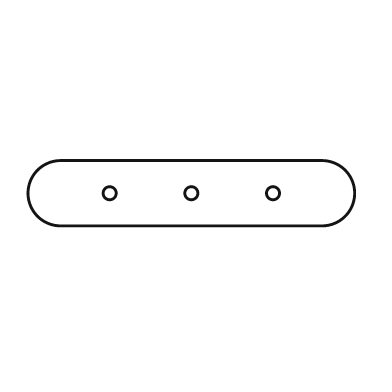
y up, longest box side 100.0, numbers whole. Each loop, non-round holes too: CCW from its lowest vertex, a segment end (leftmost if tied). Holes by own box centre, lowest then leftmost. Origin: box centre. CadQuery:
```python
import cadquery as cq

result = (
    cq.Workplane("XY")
    .moveTo(-40.0, -10.0)
    .lineTo(40.0, -10.0)
    .threePointArc((50.0, 0.0), (40.0, 10.0))
    .lineTo(-40.0, 10.0)
    .threePointArc((-50.0, 0.0), (-40.0, -10.0))
    .close()
    .moveTo(-25.0, 0.0)
    .circle(2.0)
    .moveTo(0.0, 0.0)
    .circle(2.0)
    .moveTo(25.0, 0.0)
    .circle(2.0)
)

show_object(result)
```